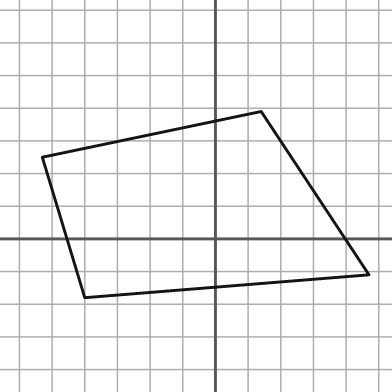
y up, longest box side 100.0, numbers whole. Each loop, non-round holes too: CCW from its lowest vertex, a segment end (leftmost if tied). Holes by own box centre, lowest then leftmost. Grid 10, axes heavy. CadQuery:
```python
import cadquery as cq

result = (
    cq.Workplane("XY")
    .moveTo(-40.0, -18.0)
    .lineTo(47.0, -11.0)
    .lineTo(14.0, 39.0)
    .lineTo(-53.0, 25.0)
    .close()
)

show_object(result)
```